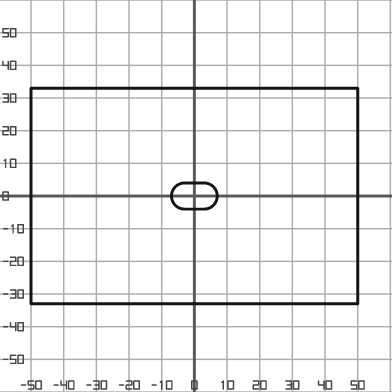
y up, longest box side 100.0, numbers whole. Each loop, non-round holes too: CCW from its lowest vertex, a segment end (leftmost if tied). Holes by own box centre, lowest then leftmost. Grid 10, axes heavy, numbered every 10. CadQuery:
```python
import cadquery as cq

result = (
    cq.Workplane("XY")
    .moveTo(-50.0, -33.0)
    .lineTo(50.0, -33.0)
    .lineTo(50.0, 33.0)
    .lineTo(-50.0, 33.0)
    .close()
    .moveTo(-3.0, -4.0)
    .lineTo(3.0, -4.0)
    .threePointArc((7.0, 0.0), (3.0, 4.0))
    .lineTo(-3.0, 4.0)
    .threePointArc((-7.0, 0.0), (-3.0, -4.0))
    .close()
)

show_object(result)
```